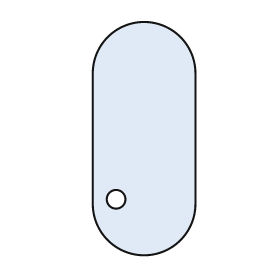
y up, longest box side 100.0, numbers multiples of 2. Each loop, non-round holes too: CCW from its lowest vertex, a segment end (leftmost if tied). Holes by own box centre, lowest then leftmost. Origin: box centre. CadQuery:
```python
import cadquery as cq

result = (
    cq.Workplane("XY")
    .moveTo(-22.0, -28.0)
    .threePointArc((0.0, -50.0), (22.0, -28.0))
    .lineTo(22.0, 28.0)
    .threePointArc((0.0, 50.0), (-22.0, 28.0))
    .close()
    .moveTo(-12.0, -26.0)
    .circle(4.0)
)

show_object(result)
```